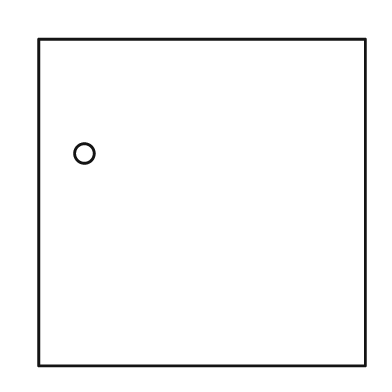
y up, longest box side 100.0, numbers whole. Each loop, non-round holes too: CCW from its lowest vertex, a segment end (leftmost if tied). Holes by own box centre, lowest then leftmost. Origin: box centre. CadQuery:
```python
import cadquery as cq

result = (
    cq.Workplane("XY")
    .moveTo(-50.0, -50.0)
    .lineTo(50.0, -50.0)
    .lineTo(50.0, 50.0)
    .lineTo(-50.0, 50.0)
    .close()
    .moveTo(-36.0, 15.0)
    .circle(3.0)
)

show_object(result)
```